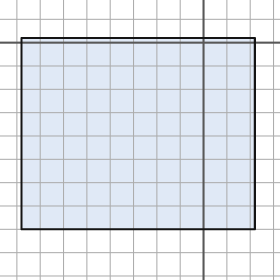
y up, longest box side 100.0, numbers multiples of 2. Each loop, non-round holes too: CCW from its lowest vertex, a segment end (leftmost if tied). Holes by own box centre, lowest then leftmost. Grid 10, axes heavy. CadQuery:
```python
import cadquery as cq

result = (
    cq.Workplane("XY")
    .moveTo(-78.0, -80.0)
    .lineTo(22.0, -80.0)
    .lineTo(22.0, 2.0)
    .lineTo(-78.0, 2.0)
    .close()
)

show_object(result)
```